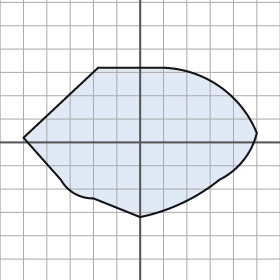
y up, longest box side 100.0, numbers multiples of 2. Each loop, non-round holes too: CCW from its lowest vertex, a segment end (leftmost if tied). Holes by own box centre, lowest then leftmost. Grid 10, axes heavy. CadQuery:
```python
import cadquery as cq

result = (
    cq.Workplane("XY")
    .moveTo(0.0, -32.0)
    .threePointArc((18.0, -26.0), (34.0, -16.0))
    .threePointArc((44.0, -8.0), (50.0, 4.0))
    .threePointArc((34.0, 24.0), (10.0, 32.0))
    .lineTo(-18.0, 32.0)
    .lineTo(-50.0, 2.0)
    .lineTo(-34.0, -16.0)
    .threePointArc((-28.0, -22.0), (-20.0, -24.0))
    .close()
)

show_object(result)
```